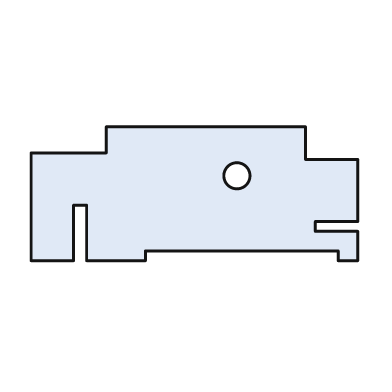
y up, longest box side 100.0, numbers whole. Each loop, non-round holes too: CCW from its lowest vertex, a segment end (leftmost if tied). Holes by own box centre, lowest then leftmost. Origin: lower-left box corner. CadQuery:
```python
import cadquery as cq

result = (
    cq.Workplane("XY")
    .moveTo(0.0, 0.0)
    .lineTo(13.0, 0.0)
    .lineTo(13.0, 17.0)
    .lineTo(17.0, 17.0)
    .lineTo(17.0, 0.0)
    .lineTo(35.0, 0.0)
    .lineTo(35.0, 3.0)
    .lineTo(94.0, 3.0)
    .lineTo(94.0, 0.0)
    .lineTo(100.0, 0.0)
    .lineTo(100.0, 9.0)
    .lineTo(87.0, 9.0)
    .lineTo(87.0, 12.0)
    .lineTo(100.0, 12.0)
    .lineTo(100.0, 31.0)
    .lineTo(84.0, 31.0)
    .lineTo(84.0, 41.0)
    .lineTo(23.0, 41.0)
    .lineTo(23.0, 33.0)
    .lineTo(0.0, 33.0)
    .close()
    .moveTo(63.0, 26.0)
    .circle(4.0)
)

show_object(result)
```